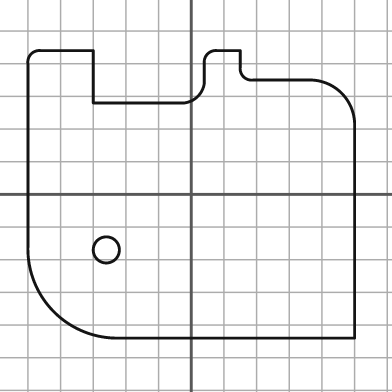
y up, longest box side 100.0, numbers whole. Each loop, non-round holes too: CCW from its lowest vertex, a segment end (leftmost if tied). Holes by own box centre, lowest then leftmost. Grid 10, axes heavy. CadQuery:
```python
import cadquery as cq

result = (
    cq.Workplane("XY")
    .moveTo(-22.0, -44.0)
    .lineTo(50.0, -44.0)
    .lineTo(50.0, 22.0)
    .threePointArc((46.0, 31.0), (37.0, 35.0))
    .lineTo(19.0, 35.0)
    .threePointArc((16.0, 36.0), (15.0, 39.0))
    .lineTo(15.0, 44.0)
    .lineTo(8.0, 44.0)
    .threePointArc((5.0, 43.0), (4.0, 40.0))
    .lineTo(4.0, 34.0)
    .threePointArc((2.0, 30.0), (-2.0, 28.0))
    .lineTo(-30.0, 28.0)
    .lineTo(-30.0, 44.0)
    .lineTo(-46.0, 44.0)
    .threePointArc((-49.0, 43.0), (-50.0, 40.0))
    .lineTo(-50.0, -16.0)
    .threePointArc((-42.0, -36.0), (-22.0, -44.0))
    .close()
    .moveTo(-26.0, -17.0)
    .circle(4.0)
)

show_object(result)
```